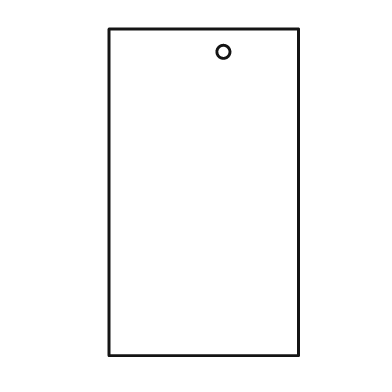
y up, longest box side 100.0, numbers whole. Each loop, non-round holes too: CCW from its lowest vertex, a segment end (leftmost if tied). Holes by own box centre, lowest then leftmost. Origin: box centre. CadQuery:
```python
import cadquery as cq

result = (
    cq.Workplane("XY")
    .moveTo(-29.0, -50.0)
    .lineTo(29.0, -50.0)
    .lineTo(29.0, 50.0)
    .lineTo(-29.0, 50.0)
    .close()
    .moveTo(6.0, 43.0)
    .circle(2.0)
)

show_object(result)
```